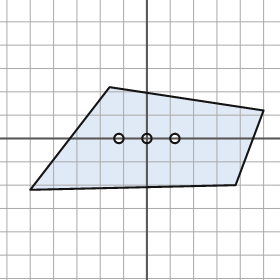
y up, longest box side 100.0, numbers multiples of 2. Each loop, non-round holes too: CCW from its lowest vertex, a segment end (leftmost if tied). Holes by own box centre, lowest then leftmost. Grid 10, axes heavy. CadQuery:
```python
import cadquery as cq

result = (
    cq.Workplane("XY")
    .moveTo(-50.0, -22.0)
    .lineTo(38.0, -20.0)
    .lineTo(50.0, 12.0)
    .lineTo(-16.0, 22.0)
    .close()
    .moveTo(-12.0, 0.0)
    .circle(2.0)
    .moveTo(0.0, 0.0)
    .circle(2.0)
    .moveTo(12.0, 0.0)
    .circle(2.0)
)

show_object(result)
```